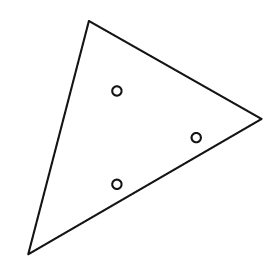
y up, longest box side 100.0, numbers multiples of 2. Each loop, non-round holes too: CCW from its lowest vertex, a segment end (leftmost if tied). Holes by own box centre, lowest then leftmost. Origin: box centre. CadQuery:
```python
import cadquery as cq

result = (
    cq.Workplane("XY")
    .moveTo(-50.0, -50.0)
    .lineTo(50.0, 8.0)
    .lineTo(-24.0, 50.0)
    .close()
    .moveTo(-12.0, -20.0)
    .circle(2.0)
    .moveTo(22.0, 0.0)
    .circle(2.0)
    .moveTo(-12.0, 20.0)
    .circle(2.0)
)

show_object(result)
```